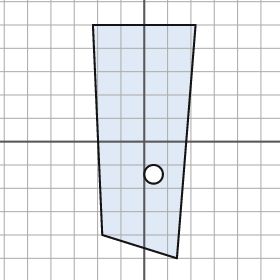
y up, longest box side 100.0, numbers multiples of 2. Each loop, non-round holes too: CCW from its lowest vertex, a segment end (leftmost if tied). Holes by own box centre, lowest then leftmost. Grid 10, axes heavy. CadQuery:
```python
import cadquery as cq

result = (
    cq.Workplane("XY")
    .moveTo(14.0, -50.0)
    .lineTo(22.0, 50.0)
    .lineTo(-22.0, 50.0)
    .lineTo(-18.0, -40.0)
    .close()
    .moveTo(4.0, -14.0)
    .circle(4.0)
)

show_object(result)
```